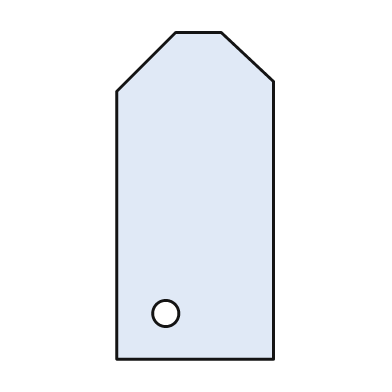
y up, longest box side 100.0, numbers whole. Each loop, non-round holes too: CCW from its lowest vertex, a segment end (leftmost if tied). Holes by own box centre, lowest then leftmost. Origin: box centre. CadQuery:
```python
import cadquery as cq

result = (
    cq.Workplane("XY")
    .moveTo(-24.0, -50.0)
    .lineTo(24.0, -50.0)
    .lineTo(24.0, 35.0)
    .lineTo(8.0, 50.0)
    .lineTo(-6.0, 50.0)
    .lineTo(-24.0, 32.0)
    .close()
    .moveTo(-9.0, -36.0)
    .circle(4.0)
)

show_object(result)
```